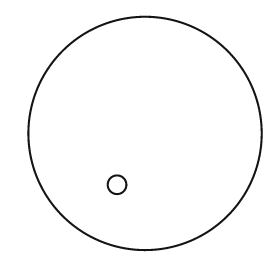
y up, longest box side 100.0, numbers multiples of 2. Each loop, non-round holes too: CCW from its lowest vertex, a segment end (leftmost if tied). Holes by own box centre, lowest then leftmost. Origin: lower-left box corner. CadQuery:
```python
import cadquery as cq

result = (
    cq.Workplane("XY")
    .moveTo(50.0, 50.0)
    .circle(50.0)
    .moveTo(38.0, 28.0)
    .circle(4.0)
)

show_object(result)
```